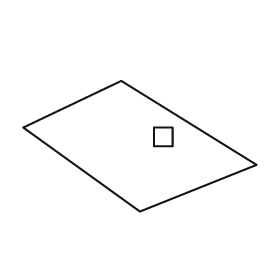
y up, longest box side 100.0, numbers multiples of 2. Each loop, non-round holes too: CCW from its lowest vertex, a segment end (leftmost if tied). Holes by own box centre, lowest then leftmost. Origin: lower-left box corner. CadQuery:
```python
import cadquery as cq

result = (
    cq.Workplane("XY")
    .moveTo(50.0, 0.0)
    .lineTo(100.0, 20.0)
    .lineTo(42.0, 56.0)
    .lineTo(0.0, 36.0)
    .close()
    .moveTo(56.0, 28.0)
    .lineTo(64.0, 28.0)
    .lineTo(64.0, 36.0)
    .lineTo(56.0, 36.0)
    .close()
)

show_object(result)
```